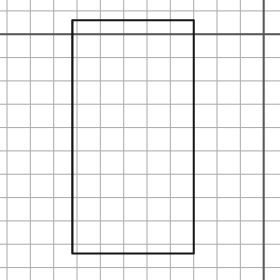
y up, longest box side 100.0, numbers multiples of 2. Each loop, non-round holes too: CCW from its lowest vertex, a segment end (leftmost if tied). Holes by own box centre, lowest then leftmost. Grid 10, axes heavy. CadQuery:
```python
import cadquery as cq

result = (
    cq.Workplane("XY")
    .moveTo(-82.0, -94.0)
    .lineTo(-30.0, -94.0)
    .lineTo(-30.0, 6.0)
    .lineTo(-82.0, 6.0)
    .close()
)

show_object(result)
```